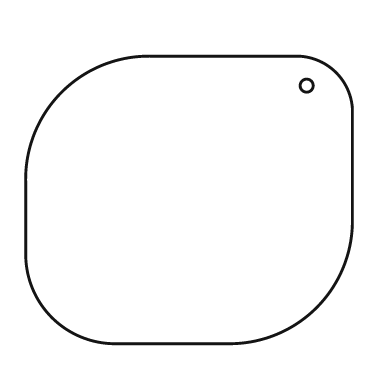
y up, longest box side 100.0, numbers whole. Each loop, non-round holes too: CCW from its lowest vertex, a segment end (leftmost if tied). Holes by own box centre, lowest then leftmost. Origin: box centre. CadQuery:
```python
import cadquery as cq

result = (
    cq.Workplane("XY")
    .moveTo(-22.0, -44.0)
    .lineTo(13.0, -44.0)
    .threePointArc((39.0, -33.0), (50.0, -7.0))
    .lineTo(50.0, 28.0)
    .threePointArc((45.0, 39.0), (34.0, 44.0))
    .lineTo(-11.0, 44.0)
    .threePointArc((-39.0, 33.0), (-50.0, 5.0))
    .lineTo(-50.0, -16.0)
    .threePointArc((-42.0, -36.0), (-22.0, -44.0))
    .close()
    .moveTo(36.0, 35.0)
    .circle(2.0)
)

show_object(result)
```